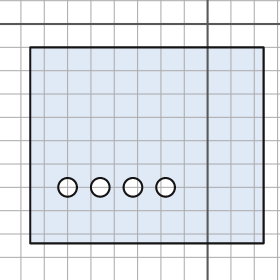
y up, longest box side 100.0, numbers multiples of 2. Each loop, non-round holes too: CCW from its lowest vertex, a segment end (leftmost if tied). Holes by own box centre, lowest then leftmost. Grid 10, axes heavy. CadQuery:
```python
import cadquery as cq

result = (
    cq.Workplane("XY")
    .moveTo(-76.0, -94.0)
    .lineTo(24.0, -94.0)
    .lineTo(24.0, -10.0)
    .lineTo(-76.0, -10.0)
    .close()
    .moveTo(-60.0, -70.0)
    .circle(4.0)
    .moveTo(-46.0, -70.0)
    .circle(4.0)
    .moveTo(-32.0, -70.0)
    .circle(4.0)
    .moveTo(-18.0, -70.0)
    .circle(4.0)
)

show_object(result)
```